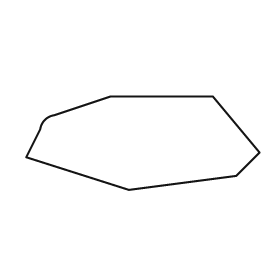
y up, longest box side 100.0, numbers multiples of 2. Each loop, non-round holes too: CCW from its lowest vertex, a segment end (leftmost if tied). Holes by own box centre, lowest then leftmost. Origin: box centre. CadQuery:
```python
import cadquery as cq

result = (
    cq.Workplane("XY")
    .moveTo(-6.0, -20.0)
    .lineTo(40.0, -14.0)
    .lineTo(50.0, -4.0)
    .lineTo(30.0, 20.0)
    .lineTo(-14.0, 20.0)
    .lineTo(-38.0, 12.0)
    .threePointArc((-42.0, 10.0), (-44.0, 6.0))
    .lineTo(-50.0, -6.0)
    .close()
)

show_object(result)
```